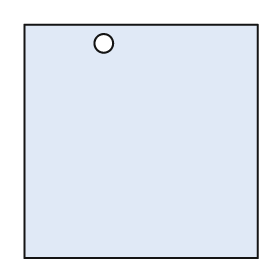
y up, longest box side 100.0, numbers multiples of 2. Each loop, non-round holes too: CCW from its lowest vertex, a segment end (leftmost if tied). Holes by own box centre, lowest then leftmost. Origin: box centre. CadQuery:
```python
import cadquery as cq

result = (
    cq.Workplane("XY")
    .moveTo(-50.0, -50.0)
    .lineTo(50.0, -50.0)
    .lineTo(50.0, 50.0)
    .lineTo(-50.0, 50.0)
    .close()
    .moveTo(-16.0, 42.0)
    .circle(4.0)
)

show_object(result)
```